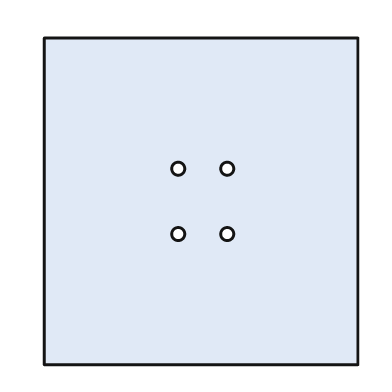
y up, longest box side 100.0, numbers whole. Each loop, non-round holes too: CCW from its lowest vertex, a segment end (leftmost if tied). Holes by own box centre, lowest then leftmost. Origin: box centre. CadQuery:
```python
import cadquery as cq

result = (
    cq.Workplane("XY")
    .moveTo(-48.0, -50.0)
    .lineTo(48.0, -50.0)
    .lineTo(48.0, 50.0)
    .lineTo(-48.0, 50.0)
    .close()
    .moveTo(-7.0, -10.0)
    .circle(2.0)
    .moveTo(8.0, -10.0)
    .circle(2.0)
    .moveTo(-7.0, 10.0)
    .circle(2.0)
    .moveTo(8.0, 10.0)
    .circle(2.0)
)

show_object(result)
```